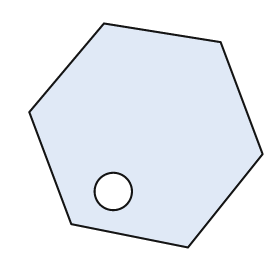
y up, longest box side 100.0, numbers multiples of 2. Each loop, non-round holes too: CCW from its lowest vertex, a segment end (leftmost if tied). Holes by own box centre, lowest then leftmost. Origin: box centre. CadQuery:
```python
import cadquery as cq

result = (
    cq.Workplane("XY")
    .moveTo(18.0, -48.0)
    .lineTo(50.0, -8.0)
    .lineTo(32.0, 40.0)
    .lineTo(-18.0, 48.0)
    .lineTo(-50.0, 10.0)
    .lineTo(-32.0, -38.0)
    .close()
    .moveTo(-14.0, -24.0)
    .circle(8.0)
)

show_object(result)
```